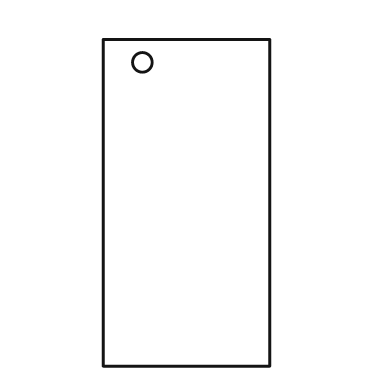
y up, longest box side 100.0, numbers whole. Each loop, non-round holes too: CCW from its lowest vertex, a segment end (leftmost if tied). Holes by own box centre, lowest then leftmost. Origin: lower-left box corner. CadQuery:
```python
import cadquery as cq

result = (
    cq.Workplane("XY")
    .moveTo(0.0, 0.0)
    .lineTo(51.0, 0.0)
    .lineTo(51.0, 100.0)
    .lineTo(0.0, 100.0)
    .close()
    .moveTo(12.0, 93.0)
    .circle(3.0)
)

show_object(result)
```